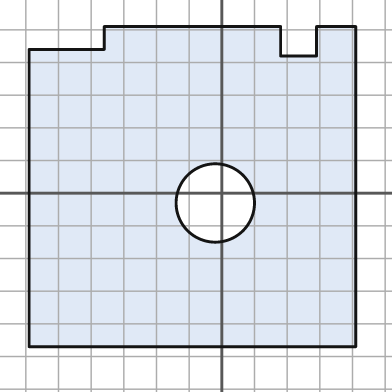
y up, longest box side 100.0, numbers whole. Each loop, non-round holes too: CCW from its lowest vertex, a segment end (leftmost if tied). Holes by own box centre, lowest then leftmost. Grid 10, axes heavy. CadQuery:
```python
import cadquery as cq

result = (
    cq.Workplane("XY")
    .moveTo(-59.0, -47.0)
    .lineTo(41.0, -47.0)
    .lineTo(41.0, 51.0)
    .lineTo(29.0, 51.0)
    .lineTo(29.0, 42.0)
    .lineTo(18.0, 42.0)
    .lineTo(18.0, 51.0)
    .lineTo(-36.0, 51.0)
    .lineTo(-36.0, 44.0)
    .lineTo(-59.0, 44.0)
    .close()
    .moveTo(-2.0, -3.0)
    .circle(12.0)
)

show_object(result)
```